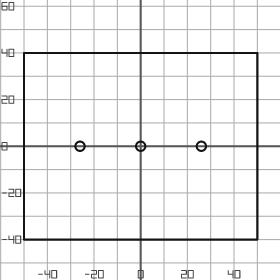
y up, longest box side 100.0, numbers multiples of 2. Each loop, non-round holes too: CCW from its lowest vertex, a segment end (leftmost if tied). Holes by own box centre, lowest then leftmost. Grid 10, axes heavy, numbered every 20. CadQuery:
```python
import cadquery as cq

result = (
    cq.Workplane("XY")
    .moveTo(-50.0, -40.0)
    .lineTo(50.0, -40.0)
    .lineTo(50.0, 40.0)
    .lineTo(-50.0, 40.0)
    .close()
    .moveTo(-26.0, 0.0)
    .circle(2.0)
    .moveTo(0.0, 0.0)
    .circle(2.0)
    .moveTo(26.0, 0.0)
    .circle(2.0)
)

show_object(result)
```